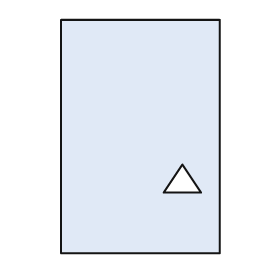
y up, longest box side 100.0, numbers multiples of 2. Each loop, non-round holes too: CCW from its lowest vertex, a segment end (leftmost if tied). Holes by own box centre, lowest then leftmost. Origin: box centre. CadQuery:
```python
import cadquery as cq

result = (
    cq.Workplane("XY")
    .moveTo(-34.0, -50.0)
    .lineTo(34.0, -50.0)
    .lineTo(34.0, 50.0)
    .lineTo(-34.0, 50.0)
    .close()
    .moveTo(10.0, -24.0)
    .lineTo(26.0, -24.0)
    .lineTo(18.0, -12.0)
    .close()
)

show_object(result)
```